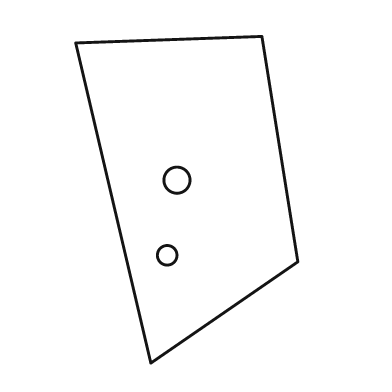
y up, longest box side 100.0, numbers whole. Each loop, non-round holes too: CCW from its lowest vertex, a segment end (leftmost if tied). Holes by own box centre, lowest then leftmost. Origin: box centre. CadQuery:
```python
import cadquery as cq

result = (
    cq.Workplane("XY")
    .moveTo(-11.0, -50.0)
    .lineTo(34.0, -19.0)
    .lineTo(23.0, 50.0)
    .lineTo(-34.0, 48.0)
    .close()
    .moveTo(-6.0, -17.0)
    .circle(3.0)
    .moveTo(-3.0, 6.0)
    .circle(4.0)
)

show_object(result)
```